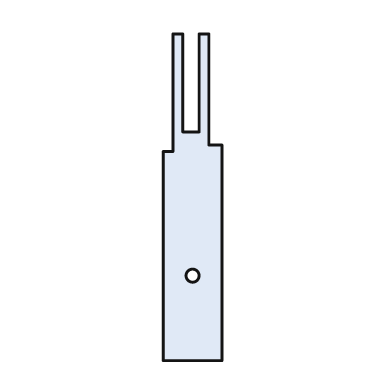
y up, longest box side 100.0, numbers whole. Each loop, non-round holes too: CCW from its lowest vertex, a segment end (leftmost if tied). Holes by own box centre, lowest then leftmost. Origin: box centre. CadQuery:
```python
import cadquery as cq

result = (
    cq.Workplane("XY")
    .moveTo(-9.0, -50.0)
    .lineTo(9.0, -50.0)
    .lineTo(9.0, 16.0)
    .lineTo(5.0, 16.0)
    .lineTo(5.0, 50.0)
    .lineTo(2.0, 50.0)
    .lineTo(2.0, 20.0)
    .lineTo(-3.0, 20.0)
    .lineTo(-3.0, 50.0)
    .lineTo(-6.0, 50.0)
    .lineTo(-6.0, 14.0)
    .lineTo(-9.0, 14.0)
    .close()
    .moveTo(0.0, -24.0)
    .circle(2.0)
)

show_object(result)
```